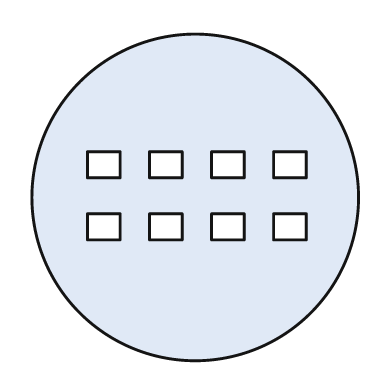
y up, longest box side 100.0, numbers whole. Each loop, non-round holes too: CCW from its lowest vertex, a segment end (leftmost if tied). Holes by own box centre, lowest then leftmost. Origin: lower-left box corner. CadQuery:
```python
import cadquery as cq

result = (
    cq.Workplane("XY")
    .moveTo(50.0, 50.0)
    .circle(50.0)
    .moveTo(17.0, 37.0)
    .lineTo(27.0, 37.0)
    .lineTo(27.0, 45.0)
    .lineTo(17.0, 45.0)
    .close()
    .moveTo(36.0, 37.0)
    .lineTo(46.0, 37.0)
    .lineTo(46.0, 45.0)
    .lineTo(36.0, 45.0)
    .close()
    .moveTo(55.0, 37.0)
    .lineTo(65.0, 37.0)
    .lineTo(65.0, 45.0)
    .lineTo(55.0, 45.0)
    .close()
    .moveTo(74.0, 37.0)
    .lineTo(84.0, 37.0)
    .lineTo(84.0, 45.0)
    .lineTo(74.0, 45.0)
    .close()
    .moveTo(17.0, 56.0)
    .lineTo(27.0, 56.0)
    .lineTo(27.0, 64.0)
    .lineTo(17.0, 64.0)
    .close()
    .moveTo(36.0, 56.0)
    .lineTo(46.0, 56.0)
    .lineTo(46.0, 64.0)
    .lineTo(36.0, 64.0)
    .close()
    .moveTo(55.0, 56.0)
    .lineTo(65.0, 56.0)
    .lineTo(65.0, 64.0)
    .lineTo(55.0, 64.0)
    .close()
    .moveTo(74.0, 56.0)
    .lineTo(84.0, 56.0)
    .lineTo(84.0, 64.0)
    .lineTo(74.0, 64.0)
    .close()
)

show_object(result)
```